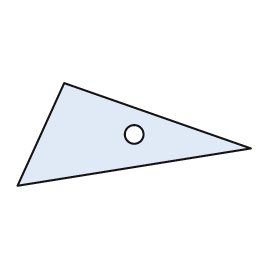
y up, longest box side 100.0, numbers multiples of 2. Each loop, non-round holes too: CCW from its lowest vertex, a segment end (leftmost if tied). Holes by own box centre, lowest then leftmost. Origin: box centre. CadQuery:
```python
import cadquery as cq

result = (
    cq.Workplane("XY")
    .moveTo(-50.0, -22.0)
    .lineTo(50.0, -6.0)
    .lineTo(-30.0, 22.0)
    .close()
    .moveTo(0.0, 0.0)
    .circle(4.0)
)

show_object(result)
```